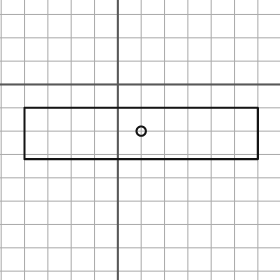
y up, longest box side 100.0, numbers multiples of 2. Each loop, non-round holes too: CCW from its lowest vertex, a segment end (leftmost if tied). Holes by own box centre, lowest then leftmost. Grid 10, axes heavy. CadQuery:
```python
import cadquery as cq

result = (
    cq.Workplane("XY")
    .moveTo(-40.0, -32.0)
    .lineTo(60.0, -32.0)
    .lineTo(60.0, -10.0)
    .lineTo(-40.0, -10.0)
    .close()
    .moveTo(10.0, -20.0)
    .circle(2.0)
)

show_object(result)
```